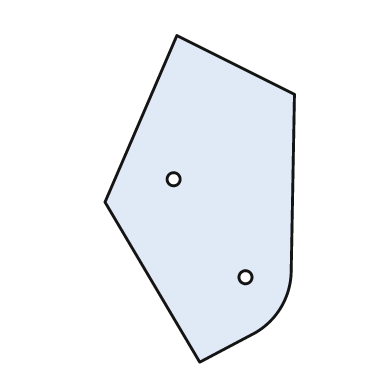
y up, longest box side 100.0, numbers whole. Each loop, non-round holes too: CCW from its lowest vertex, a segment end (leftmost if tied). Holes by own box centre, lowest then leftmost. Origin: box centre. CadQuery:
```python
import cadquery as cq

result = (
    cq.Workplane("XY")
    .moveTo(0.0, -50.0)
    .lineTo(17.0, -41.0)
    .threePointArc((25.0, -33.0), (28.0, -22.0))
    .lineTo(29.0, 32.0)
    .lineTo(-7.0, 50.0)
    .lineTo(-29.0, -1.0)
    .close()
    .moveTo(14.0, -24.0)
    .circle(2.0)
    .moveTo(-8.0, 6.0)
    .circle(2.0)
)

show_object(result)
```